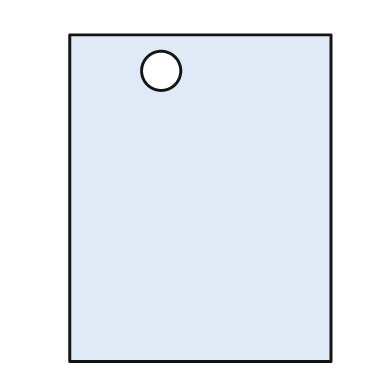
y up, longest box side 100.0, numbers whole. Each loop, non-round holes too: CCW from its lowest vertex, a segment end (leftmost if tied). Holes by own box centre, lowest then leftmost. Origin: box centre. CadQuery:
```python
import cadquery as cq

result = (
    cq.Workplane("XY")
    .moveTo(-40.0, -50.0)
    .lineTo(40.0, -50.0)
    .lineTo(40.0, 50.0)
    .lineTo(-40.0, 50.0)
    .close()
    .moveTo(-12.0, 39.0)
    .circle(6.0)
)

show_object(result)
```